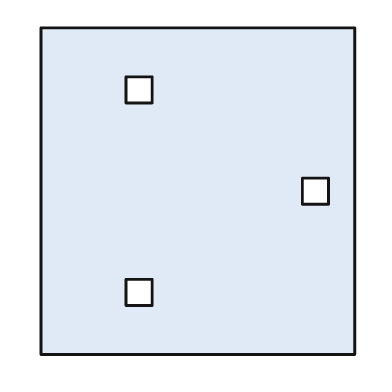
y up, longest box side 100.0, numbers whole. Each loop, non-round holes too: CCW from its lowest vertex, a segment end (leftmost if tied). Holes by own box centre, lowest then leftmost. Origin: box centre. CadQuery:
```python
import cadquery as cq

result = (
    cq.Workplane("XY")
    .moveTo(-48.0, -50.0)
    .lineTo(48.0, -50.0)
    .lineTo(48.0, 50.0)
    .lineTo(-48.0, 50.0)
    .close()
    .moveTo(-22.0, -35.0)
    .lineTo(-14.0, -35.0)
    .lineTo(-14.0, -27.0)
    .lineTo(-22.0, -27.0)
    .close()
    .moveTo(32.0, -4.0)
    .lineTo(40.0, -4.0)
    .lineTo(40.0, 4.0)
    .lineTo(32.0, 4.0)
    .close()
    .moveTo(-22.0, 27.0)
    .lineTo(-14.0, 27.0)
    .lineTo(-14.0, 35.0)
    .lineTo(-22.0, 35.0)
    .close()
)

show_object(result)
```